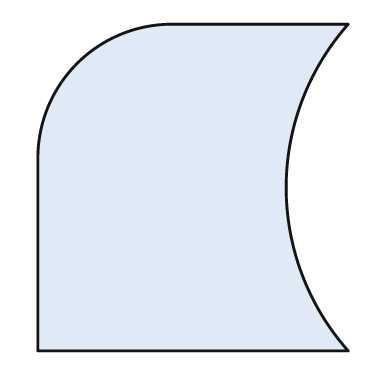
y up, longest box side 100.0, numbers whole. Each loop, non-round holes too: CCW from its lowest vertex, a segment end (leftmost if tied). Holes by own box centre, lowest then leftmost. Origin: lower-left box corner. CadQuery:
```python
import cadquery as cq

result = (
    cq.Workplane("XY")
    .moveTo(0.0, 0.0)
    .lineTo(95.0, 0.0)
    .threePointArc((76.0, 50.0), (95.0, 100.0))
    .lineTo(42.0, 100.0)
    .threePointArc((12.0, 88.0), (0.0, 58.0))
    .close()
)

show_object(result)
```